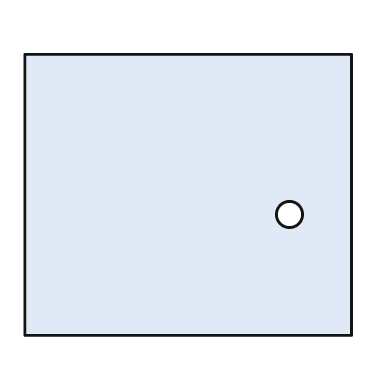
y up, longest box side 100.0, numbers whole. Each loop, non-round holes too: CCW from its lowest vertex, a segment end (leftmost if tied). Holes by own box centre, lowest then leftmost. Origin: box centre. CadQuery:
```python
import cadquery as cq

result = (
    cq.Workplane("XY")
    .moveTo(-50.0, -43.0)
    .lineTo(50.0, -43.0)
    .lineTo(50.0, 43.0)
    .lineTo(-50.0, 43.0)
    .close()
    .moveTo(31.0, -6.0)
    .circle(4.0)
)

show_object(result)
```